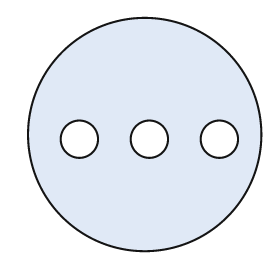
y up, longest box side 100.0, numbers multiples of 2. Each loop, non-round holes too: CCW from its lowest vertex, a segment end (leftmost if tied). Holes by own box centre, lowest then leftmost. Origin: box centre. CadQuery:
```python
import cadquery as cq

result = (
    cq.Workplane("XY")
    .moveTo(0.0, 0.0)
    .circle(50.0)
    .moveTo(-28.0, -2.0)
    .circle(8.0)
    .moveTo(2.0, -2.0)
    .circle(8.0)
    .moveTo(32.0, -2.0)
    .circle(8.0)
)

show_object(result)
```